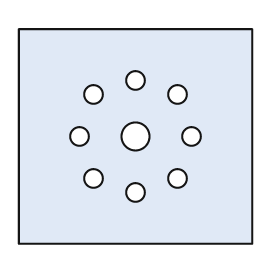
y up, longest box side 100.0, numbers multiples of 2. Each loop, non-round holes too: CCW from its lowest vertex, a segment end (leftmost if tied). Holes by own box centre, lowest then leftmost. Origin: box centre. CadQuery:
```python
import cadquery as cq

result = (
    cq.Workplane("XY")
    .moveTo(-50.0, -46.0)
    .lineTo(50.0, -46.0)
    .lineTo(50.0, 46.0)
    .lineTo(-50.0, 46.0)
    .close()
    .moveTo(0.0, -24.0)
    .circle(4.0)
    .moveTo(-18.0, -18.0)
    .circle(4.0)
    .moveTo(18.0, -18.0)
    .circle(4.0)
    .moveTo(-24.0, 0.0)
    .circle(4.0)
    .moveTo(0.0, 0.0)
    .circle(6.0)
    .moveTo(24.0, 0.0)
    .circle(4.0)
    .moveTo(-18.0, 18.0)
    .circle(4.0)
    .moveTo(18.0, 18.0)
    .circle(4.0)
    .moveTo(0.0, 24.0)
    .circle(4.0)
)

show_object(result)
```